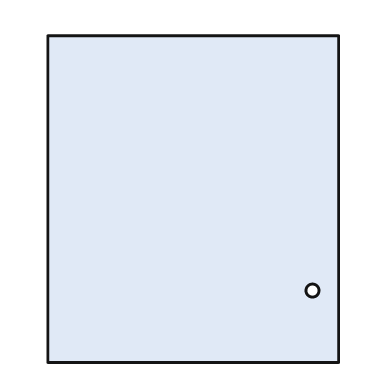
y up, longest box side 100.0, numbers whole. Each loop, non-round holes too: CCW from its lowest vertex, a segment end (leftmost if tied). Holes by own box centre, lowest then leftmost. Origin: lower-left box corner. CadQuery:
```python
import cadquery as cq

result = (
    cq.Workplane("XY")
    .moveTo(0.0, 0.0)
    .lineTo(89.0, 0.0)
    .lineTo(89.0, 100.0)
    .lineTo(0.0, 100.0)
    .close()
    .moveTo(81.0, 22.0)
    .circle(2.0)
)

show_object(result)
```